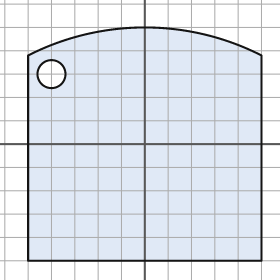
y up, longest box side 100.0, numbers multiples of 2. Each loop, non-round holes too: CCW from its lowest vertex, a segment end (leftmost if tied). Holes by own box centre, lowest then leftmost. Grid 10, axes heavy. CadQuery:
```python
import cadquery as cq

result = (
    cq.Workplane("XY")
    .moveTo(-50.0, -50.0)
    .lineTo(50.0, -50.0)
    .lineTo(50.0, 38.0)
    .threePointArc((0.0, 50.0), (-50.0, 38.0))
    .close()
    .moveTo(-40.0, 30.0)
    .circle(6.0)
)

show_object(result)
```